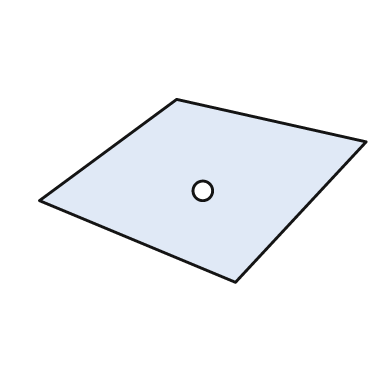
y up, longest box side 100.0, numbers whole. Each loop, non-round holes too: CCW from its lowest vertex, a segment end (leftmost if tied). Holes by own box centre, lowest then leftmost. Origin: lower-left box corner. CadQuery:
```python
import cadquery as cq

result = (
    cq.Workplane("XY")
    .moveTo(60.0, 0.0)
    .lineTo(100.0, 43.0)
    .lineTo(42.0, 56.0)
    .lineTo(0.0, 25.0)
    .close()
    .moveTo(50.0, 28.0)
    .circle(3.0)
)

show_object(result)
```